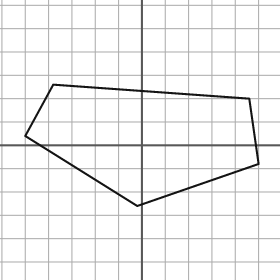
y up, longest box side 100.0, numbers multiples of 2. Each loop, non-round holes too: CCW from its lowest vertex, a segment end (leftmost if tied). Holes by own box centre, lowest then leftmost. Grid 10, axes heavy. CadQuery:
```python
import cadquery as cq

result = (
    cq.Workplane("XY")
    .moveTo(-2.0, -26.0)
    .lineTo(50.0, -8.0)
    .lineTo(46.0, 20.0)
    .lineTo(-38.0, 26.0)
    .lineTo(-50.0, 4.0)
    .close()
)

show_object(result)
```